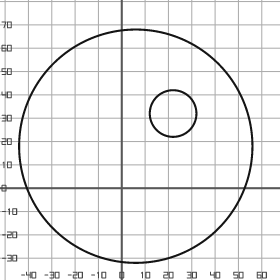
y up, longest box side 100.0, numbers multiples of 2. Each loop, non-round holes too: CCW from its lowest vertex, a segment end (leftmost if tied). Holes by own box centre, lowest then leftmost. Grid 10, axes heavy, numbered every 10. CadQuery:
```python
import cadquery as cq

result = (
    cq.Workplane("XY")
    .moveTo(6.0, 18.0)
    .circle(50.0)
    .moveTo(22.0, 32.0)
    .circle(10.0)
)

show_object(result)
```